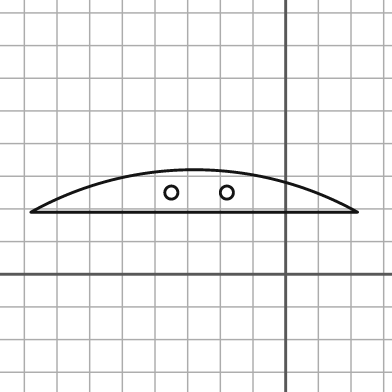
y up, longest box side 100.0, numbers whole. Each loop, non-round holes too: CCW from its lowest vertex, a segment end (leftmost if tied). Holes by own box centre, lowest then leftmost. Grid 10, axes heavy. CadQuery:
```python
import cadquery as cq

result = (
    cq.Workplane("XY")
    .moveTo(-78.0, 19.0)
    .lineTo(22.0, 19.0)
    .threePointArc((-28.0, 32.0), (-78.0, 19.0))
    .close()
    .moveTo(-35.0, 25.0)
    .circle(2.0)
    .moveTo(-18.0, 25.0)
    .circle(2.0)
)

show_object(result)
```